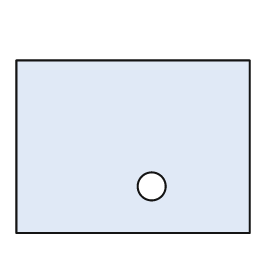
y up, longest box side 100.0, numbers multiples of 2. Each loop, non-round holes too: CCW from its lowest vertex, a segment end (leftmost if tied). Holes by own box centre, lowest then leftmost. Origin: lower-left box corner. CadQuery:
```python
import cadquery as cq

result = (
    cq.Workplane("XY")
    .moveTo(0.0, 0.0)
    .lineTo(100.0, 0.0)
    .lineTo(100.0, 74.0)
    .lineTo(0.0, 74.0)
    .close()
    .moveTo(58.0, 20.0)
    .circle(6.0)
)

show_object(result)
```